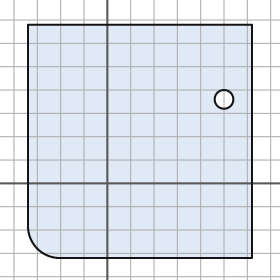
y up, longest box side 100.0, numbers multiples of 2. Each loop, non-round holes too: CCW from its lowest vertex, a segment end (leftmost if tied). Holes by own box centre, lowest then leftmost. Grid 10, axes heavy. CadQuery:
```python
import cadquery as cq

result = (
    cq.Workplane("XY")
    .moveTo(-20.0, -32.0)
    .lineTo(62.0, -32.0)
    .lineTo(62.0, 68.0)
    .lineTo(-34.0, 68.0)
    .lineTo(-34.0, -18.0)
    .threePointArc((-30.0, -28.0), (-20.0, -32.0))
    .close()
    .moveTo(50.0, 36.0)
    .circle(4.0)
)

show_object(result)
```